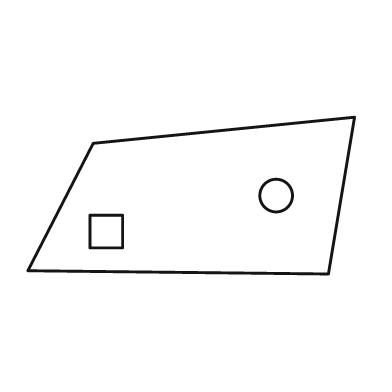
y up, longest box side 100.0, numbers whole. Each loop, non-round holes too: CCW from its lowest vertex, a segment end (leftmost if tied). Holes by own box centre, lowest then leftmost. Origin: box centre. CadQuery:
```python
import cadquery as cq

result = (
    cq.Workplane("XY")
    .moveTo(42.0, -24.0)
    .lineTo(50.0, 24.0)
    .lineTo(-30.0, 16.0)
    .lineTo(-50.0, -23.0)
    .close()
    .moveTo(-31.0, -16.0)
    .lineTo(-21.0, -16.0)
    .lineTo(-21.0, -6.0)
    .lineTo(-31.0, -6.0)
    .close()
    .moveTo(26.0, 0.0)
    .circle(5.0)
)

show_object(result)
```